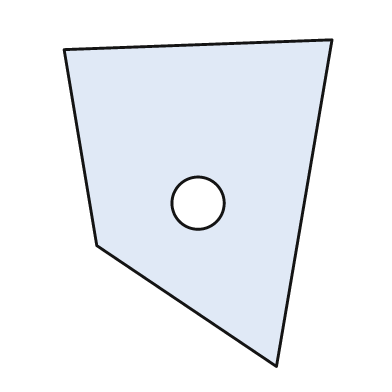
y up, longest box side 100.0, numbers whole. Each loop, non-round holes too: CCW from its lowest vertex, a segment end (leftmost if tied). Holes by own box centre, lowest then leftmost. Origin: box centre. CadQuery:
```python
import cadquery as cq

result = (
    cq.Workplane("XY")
    .moveTo(24.0, -50.0)
    .lineTo(41.0, 50.0)
    .lineTo(-41.0, 47.0)
    .lineTo(-31.0, -13.0)
    .close()
    .moveTo(0.0, 0.0)
    .circle(8.0)
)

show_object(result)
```